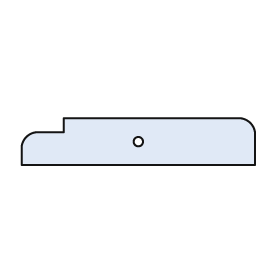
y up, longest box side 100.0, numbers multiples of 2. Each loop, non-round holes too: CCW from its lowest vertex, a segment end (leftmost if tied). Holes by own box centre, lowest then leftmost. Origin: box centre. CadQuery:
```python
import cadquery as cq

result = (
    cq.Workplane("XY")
    .moveTo(-50.0, -10.0)
    .lineTo(50.0, -10.0)
    .lineTo(50.0, 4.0)
    .threePointArc((48.0, 8.0), (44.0, 10.0))
    .lineTo(-32.0, 10.0)
    .lineTo(-32.0, 4.0)
    .lineTo(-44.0, 4.0)
    .threePointArc((-48.0, 2.0), (-50.0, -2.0))
    .close()
    .moveTo(0.0, 0.0)
    .circle(2.0)
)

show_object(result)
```